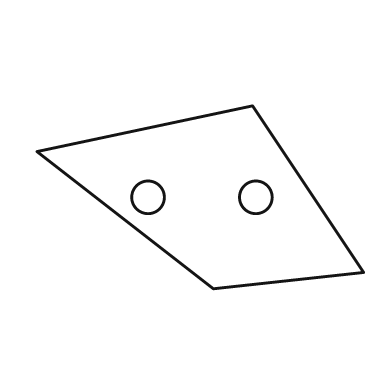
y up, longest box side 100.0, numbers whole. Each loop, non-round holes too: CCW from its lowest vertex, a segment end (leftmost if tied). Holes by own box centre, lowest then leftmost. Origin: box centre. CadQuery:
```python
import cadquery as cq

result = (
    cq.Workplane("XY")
    .moveTo(4.0, -28.0)
    .lineTo(50.0, -23.0)
    .lineTo(16.0, 28.0)
    .lineTo(-50.0, 14.0)
    .close()
    .moveTo(-16.0, 0.0)
    .circle(5.0)
    .moveTo(17.0, 0.0)
    .circle(5.0)
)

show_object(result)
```